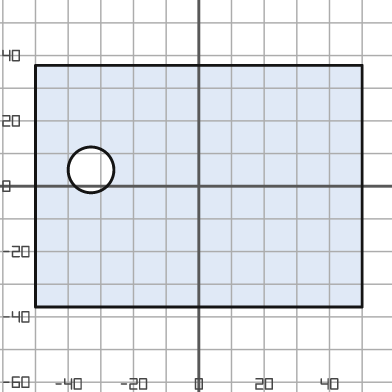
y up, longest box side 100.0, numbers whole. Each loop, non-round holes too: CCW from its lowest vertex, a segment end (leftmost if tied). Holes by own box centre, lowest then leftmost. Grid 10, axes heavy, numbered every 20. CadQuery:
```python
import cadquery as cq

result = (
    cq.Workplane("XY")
    .moveTo(-50.0, -37.0)
    .lineTo(50.0, -37.0)
    .lineTo(50.0, 37.0)
    .lineTo(-50.0, 37.0)
    .close()
    .moveTo(-33.0, 5.0)
    .circle(7.0)
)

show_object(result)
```